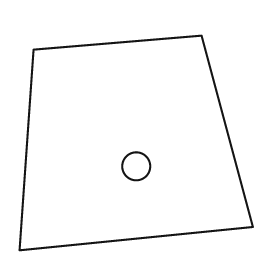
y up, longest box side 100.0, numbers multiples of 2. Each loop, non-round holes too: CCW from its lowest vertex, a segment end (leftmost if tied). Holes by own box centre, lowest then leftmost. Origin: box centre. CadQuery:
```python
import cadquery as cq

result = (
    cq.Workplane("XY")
    .moveTo(-50.0, -46.0)
    .lineTo(50.0, -36.0)
    .lineTo(28.0, 46.0)
    .lineTo(-44.0, 40.0)
    .close()
    .moveTo(0.0, -10.0)
    .circle(6.0)
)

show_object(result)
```